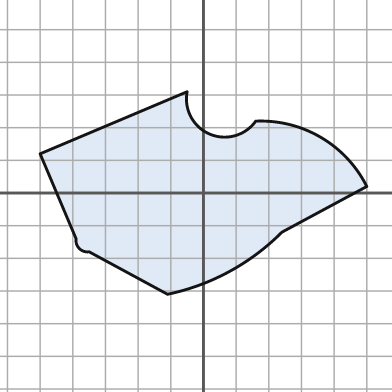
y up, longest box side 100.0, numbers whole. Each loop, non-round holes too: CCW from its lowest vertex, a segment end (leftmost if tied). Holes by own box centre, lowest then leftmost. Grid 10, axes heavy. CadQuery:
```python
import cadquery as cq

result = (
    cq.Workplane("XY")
    .moveTo(-11.0, -31.0)
    .threePointArc((8.0, -24.0), (24.0, -12.0))
    .lineTo(50.0, 2.0)
    .threePointArc((36.0, 17.0), (16.0, 22.0))
    .threePointArc((2.0, 18.0), (-5.0, 31.0))
    .lineTo(-50.0, 12.0)
    .lineTo(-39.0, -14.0)
    .threePointArc((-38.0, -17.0), (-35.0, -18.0))
    .close()
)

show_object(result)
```